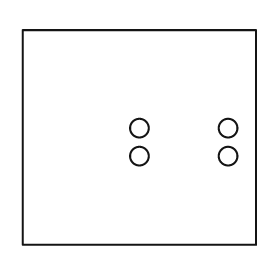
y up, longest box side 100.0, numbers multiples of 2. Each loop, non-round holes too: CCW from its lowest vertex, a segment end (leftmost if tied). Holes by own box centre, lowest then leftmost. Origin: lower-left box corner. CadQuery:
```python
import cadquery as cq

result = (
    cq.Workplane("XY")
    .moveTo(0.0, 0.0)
    .lineTo(100.0, 0.0)
    .lineTo(100.0, 92.0)
    .lineTo(0.0, 92.0)
    .close()
    .moveTo(50.0, 38.0)
    .circle(4.0)
    .moveTo(88.0, 38.0)
    .circle(4.0)
    .moveTo(50.0, 50.0)
    .circle(4.0)
    .moveTo(88.0, 50.0)
    .circle(4.0)
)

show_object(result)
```